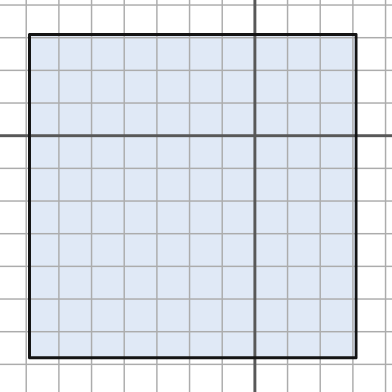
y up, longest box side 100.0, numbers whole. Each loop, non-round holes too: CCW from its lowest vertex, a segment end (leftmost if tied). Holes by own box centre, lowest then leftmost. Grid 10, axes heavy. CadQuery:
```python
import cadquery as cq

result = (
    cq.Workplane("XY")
    .moveTo(-69.0, -68.0)
    .lineTo(31.0, -68.0)
    .lineTo(31.0, 31.0)
    .lineTo(-69.0, 31.0)
    .close()
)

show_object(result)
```